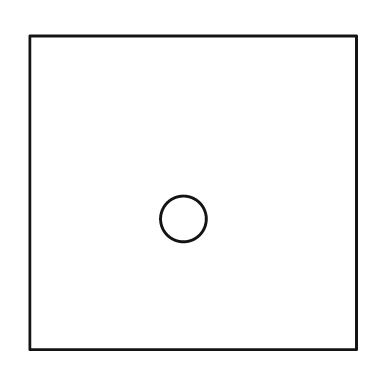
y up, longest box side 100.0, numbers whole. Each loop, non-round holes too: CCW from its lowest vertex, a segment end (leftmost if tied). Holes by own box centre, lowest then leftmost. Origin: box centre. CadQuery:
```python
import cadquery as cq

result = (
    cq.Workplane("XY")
    .moveTo(-50.0, -48.0)
    .lineTo(50.0, -48.0)
    .lineTo(50.0, 48.0)
    .lineTo(-50.0, 48.0)
    .close()
    .moveTo(-3.0, -8.0)
    .circle(7.0)
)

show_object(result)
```